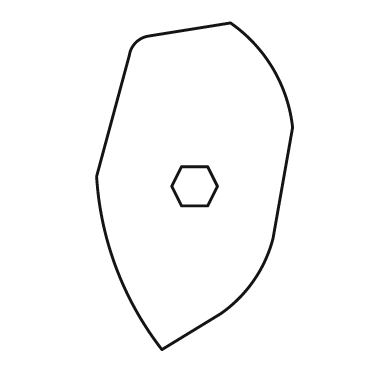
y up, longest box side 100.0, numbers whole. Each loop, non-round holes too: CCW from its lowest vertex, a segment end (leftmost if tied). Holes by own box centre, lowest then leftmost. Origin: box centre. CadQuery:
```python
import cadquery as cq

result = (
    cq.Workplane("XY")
    .moveTo(-10.0, -50.0)
    .lineTo(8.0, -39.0)
    .threePointArc((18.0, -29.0), (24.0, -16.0))
    .lineTo(30.0, 18.0)
    .threePointArc((24.0, 36.0), (11.0, 50.0))
    .lineTo(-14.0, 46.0)
    .threePointArc((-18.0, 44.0), (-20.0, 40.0))
    .lineTo(-30.0, 3.0)
    .threePointArc((-24.0, -25.0), (-10.0, -50.0))
    .close()
    .moveTo(-4.0, -6.0)
    .lineTo(4.0, -6.0)
    .lineTo(7.0, 0.0)
    .lineTo(4.0, 6.0)
    .lineTo(-4.0, 6.0)
    .lineTo(-7.0, 0.0)
    .close()
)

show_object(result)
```